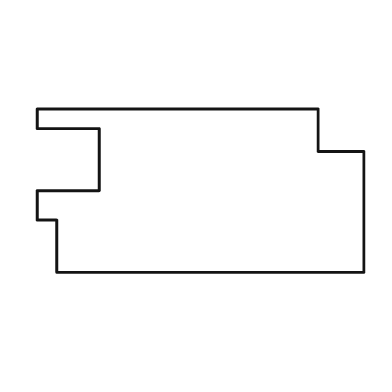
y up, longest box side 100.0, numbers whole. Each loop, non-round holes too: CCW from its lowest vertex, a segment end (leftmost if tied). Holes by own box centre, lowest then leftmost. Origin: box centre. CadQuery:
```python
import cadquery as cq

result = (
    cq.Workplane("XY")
    .moveTo(-44.0, -25.0)
    .lineTo(50.0, -25.0)
    .lineTo(50.0, 12.0)
    .lineTo(36.0, 12.0)
    .lineTo(36.0, 25.0)
    .lineTo(-50.0, 25.0)
    .lineTo(-50.0, 19.0)
    .lineTo(-31.0, 19.0)
    .lineTo(-31.0, 0.0)
    .lineTo(-50.0, 0.0)
    .lineTo(-50.0, -9.0)
    .lineTo(-44.0, -9.0)
    .close()
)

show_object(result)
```